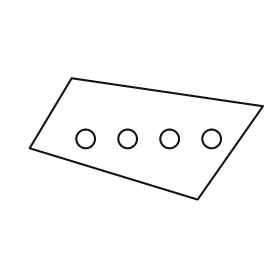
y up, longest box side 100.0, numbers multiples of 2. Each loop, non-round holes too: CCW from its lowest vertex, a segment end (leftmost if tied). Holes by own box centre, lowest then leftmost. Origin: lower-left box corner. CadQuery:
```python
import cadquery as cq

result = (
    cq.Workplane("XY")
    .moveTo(72.0, 0.0)
    .lineTo(100.0, 40.0)
    .lineTo(18.0, 52.0)
    .lineTo(0.0, 22.0)
    .close()
    .moveTo(24.0, 26.0)
    .circle(4.0)
    .moveTo(42.0, 26.0)
    .circle(4.0)
    .moveTo(60.0, 26.0)
    .circle(4.0)
    .moveTo(78.0, 26.0)
    .circle(4.0)
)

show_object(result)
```